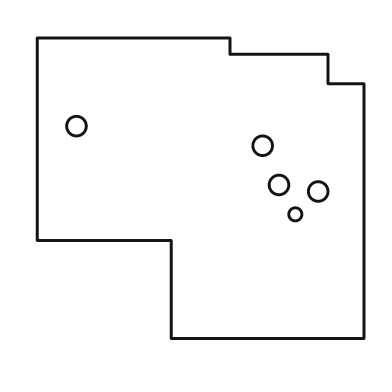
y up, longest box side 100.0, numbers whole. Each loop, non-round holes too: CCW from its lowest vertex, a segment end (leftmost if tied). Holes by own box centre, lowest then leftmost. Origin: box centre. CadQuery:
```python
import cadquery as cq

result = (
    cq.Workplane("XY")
    .moveTo(-9.0, -46.0)
    .lineTo(50.0, -46.0)
    .lineTo(50.0, 32.0)
    .lineTo(39.0, 32.0)
    .lineTo(39.0, 41.0)
    .lineTo(9.0, 41.0)
    .lineTo(9.0, 46.0)
    .lineTo(-50.0, 46.0)
    .lineTo(-50.0, -16.0)
    .lineTo(-9.0, -16.0)
    .close()
    .moveTo(29.0, -8.0)
    .circle(2.0)
    .moveTo(36.0, -1.0)
    .circle(3.0)
    .moveTo(24.0, 1.0)
    .circle(3.0)
    .moveTo(19.0, 13.0)
    .circle(3.0)
    .moveTo(-38.0, 19.0)
    .circle(3.0)
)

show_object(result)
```